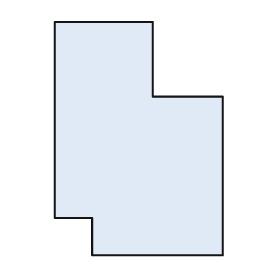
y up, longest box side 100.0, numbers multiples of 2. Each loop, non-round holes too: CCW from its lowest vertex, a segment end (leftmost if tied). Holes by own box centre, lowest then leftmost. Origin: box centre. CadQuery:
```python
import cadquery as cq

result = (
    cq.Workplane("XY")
    .moveTo(-20.0, -50.0)
    .lineTo(36.0, -50.0)
    .lineTo(36.0, 18.0)
    .lineTo(6.0, 18.0)
    .lineTo(6.0, 50.0)
    .lineTo(-36.0, 50.0)
    .lineTo(-36.0, -34.0)
    .lineTo(-20.0, -34.0)
    .close()
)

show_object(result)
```